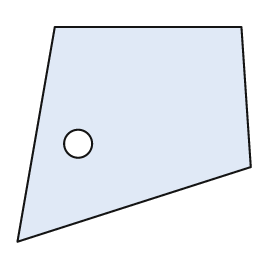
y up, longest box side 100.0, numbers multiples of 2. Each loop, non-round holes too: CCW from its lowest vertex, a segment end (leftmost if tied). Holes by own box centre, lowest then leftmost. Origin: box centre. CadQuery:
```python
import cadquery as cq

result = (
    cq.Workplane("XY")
    .moveTo(-50.0, -46.0)
    .lineTo(50.0, -14.0)
    .lineTo(46.0, 46.0)
    .lineTo(-34.0, 46.0)
    .close()
    .moveTo(-24.0, -4.0)
    .circle(6.0)
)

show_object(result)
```